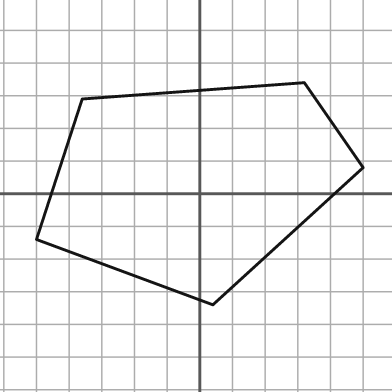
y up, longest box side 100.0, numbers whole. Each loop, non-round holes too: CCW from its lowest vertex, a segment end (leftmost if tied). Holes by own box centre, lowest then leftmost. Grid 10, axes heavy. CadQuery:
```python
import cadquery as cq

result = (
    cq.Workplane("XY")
    .moveTo(4.0, -34.0)
    .lineTo(50.0, 8.0)
    .lineTo(32.0, 34.0)
    .lineTo(-36.0, 29.0)
    .lineTo(-50.0, -14.0)
    .close()
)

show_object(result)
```